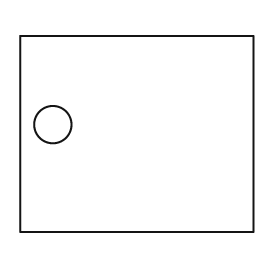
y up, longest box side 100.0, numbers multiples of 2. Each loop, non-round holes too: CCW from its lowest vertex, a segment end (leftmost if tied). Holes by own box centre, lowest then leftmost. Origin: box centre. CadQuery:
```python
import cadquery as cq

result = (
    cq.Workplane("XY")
    .moveTo(-50.0, -42.0)
    .lineTo(50.0, -42.0)
    .lineTo(50.0, 42.0)
    .lineTo(-50.0, 42.0)
    .close()
    .moveTo(-36.0, 4.0)
    .circle(8.0)
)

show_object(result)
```